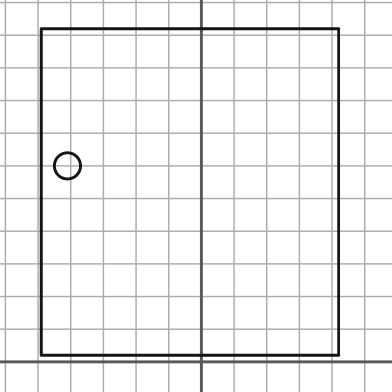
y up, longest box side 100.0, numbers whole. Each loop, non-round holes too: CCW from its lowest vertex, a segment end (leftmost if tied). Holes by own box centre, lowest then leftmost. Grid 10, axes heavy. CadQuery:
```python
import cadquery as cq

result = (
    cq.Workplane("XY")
    .moveTo(-49.0, 2.0)
    .lineTo(42.0, 2.0)
    .lineTo(42.0, 102.0)
    .lineTo(-49.0, 102.0)
    .close()
    .moveTo(-41.0, 60.0)
    .circle(4.0)
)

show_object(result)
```